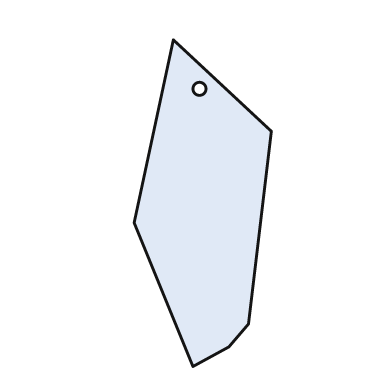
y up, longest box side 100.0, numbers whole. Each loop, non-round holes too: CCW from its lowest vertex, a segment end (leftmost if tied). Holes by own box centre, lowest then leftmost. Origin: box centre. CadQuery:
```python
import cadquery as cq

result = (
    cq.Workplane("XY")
    .moveTo(-3.0, -50.0)
    .lineTo(8.0, -44.0)
    .lineTo(14.0, -37.0)
    .lineTo(21.0, 22.0)
    .lineTo(-9.0, 50.0)
    .lineTo(-21.0, -6.0)
    .close()
    .moveTo(-1.0, 35.0)
    .circle(2.0)
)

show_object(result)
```